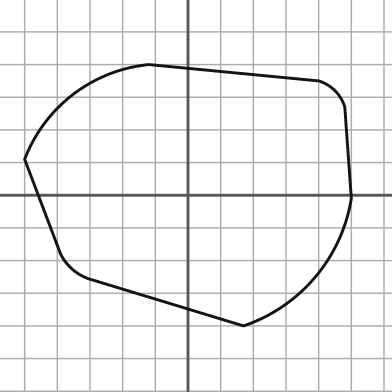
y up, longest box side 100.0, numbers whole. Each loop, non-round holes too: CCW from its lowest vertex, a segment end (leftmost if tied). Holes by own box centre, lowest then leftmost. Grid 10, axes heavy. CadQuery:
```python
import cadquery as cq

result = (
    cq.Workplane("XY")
    .moveTo(17.0, -40.0)
    .threePointArc((39.0, -25.0), (50.0, -1.0))
    .lineTo(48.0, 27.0)
    .threePointArc((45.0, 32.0), (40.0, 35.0))
    .lineTo(-12.0, 40.0)
    .threePointArc((-35.0, 31.0), (-50.0, 11.0))
    .lineTo(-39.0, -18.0)
    .threePointArc((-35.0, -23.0), (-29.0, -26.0))
    .close()
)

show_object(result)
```